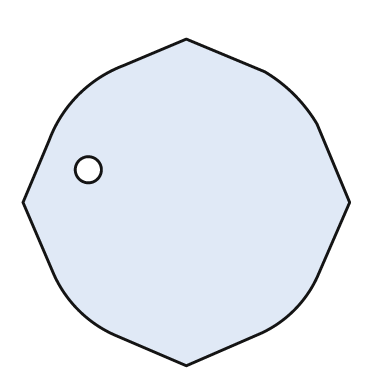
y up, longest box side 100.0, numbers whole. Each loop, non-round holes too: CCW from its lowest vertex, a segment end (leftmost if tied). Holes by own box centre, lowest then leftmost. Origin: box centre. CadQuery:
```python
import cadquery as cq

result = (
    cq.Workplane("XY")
    .moveTo(0.0, -50.0)
    .lineTo(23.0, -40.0)
    .threePointArc((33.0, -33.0), (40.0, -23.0))
    .lineTo(50.0, 0.0)
    .lineTo(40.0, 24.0)
    .threePointArc((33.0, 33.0), (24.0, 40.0))
    .lineTo(0.0, 50.0)
    .lineTo(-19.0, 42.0)
    .threePointArc((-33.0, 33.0), (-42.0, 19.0))
    .lineTo(-50.0, 0.0)
    .lineTo(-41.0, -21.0)
    .threePointArc((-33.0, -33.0), (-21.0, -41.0))
    .close()
    .moveTo(-30.0, 10.0)
    .circle(4.0)
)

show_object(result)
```